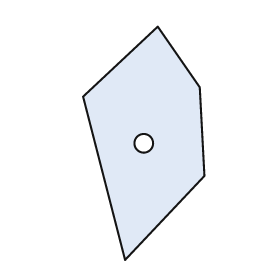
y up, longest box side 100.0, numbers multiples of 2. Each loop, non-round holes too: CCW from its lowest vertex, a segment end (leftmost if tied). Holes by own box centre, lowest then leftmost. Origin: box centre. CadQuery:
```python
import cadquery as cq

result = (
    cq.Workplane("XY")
    .moveTo(-8.0, -50.0)
    .lineTo(26.0, -14.0)
    .lineTo(24.0, 24.0)
    .lineTo(6.0, 50.0)
    .lineTo(-26.0, 20.0)
    .close()
    .moveTo(0.0, 0.0)
    .circle(4.0)
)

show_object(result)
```